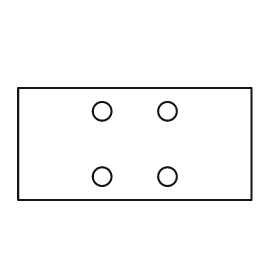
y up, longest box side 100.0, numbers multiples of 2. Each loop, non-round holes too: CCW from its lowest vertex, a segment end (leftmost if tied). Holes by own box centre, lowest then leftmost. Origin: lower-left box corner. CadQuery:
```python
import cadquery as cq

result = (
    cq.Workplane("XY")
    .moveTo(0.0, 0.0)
    .lineTo(100.0, 0.0)
    .lineTo(100.0, 48.0)
    .lineTo(0.0, 48.0)
    .close()
    .moveTo(36.0, 10.0)
    .circle(4.0)
    .moveTo(64.0, 10.0)
    .circle(4.0)
    .moveTo(36.0, 38.0)
    .circle(4.0)
    .moveTo(64.0, 38.0)
    .circle(4.0)
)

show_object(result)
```